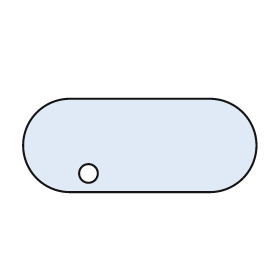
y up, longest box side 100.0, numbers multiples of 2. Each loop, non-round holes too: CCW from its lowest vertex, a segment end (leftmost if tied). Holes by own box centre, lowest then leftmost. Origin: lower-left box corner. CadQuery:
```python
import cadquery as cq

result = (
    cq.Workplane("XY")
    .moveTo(20.0, 0.0)
    .lineTo(80.0, 0.0)
    .threePointArc((100.0, 20.0), (80.0, 40.0))
    .lineTo(20.0, 40.0)
    .threePointArc((0.0, 20.0), (20.0, 0.0))
    .close()
    .moveTo(28.0, 8.0)
    .circle(4.0)
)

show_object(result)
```